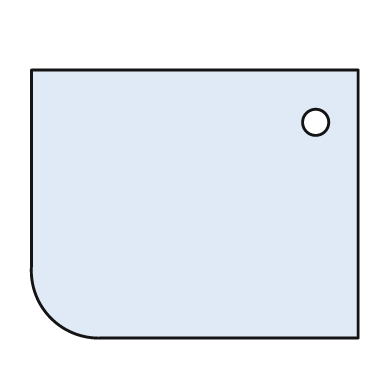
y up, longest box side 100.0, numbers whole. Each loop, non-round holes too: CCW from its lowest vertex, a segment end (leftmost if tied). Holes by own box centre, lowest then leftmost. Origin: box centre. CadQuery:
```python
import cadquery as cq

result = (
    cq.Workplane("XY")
    .moveTo(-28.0, -41.0)
    .lineTo(50.0, -41.0)
    .lineTo(50.0, 41.0)
    .lineTo(-50.0, 41.0)
    .lineTo(-50.0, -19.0)
    .threePointArc((-44.0, -35.0), (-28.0, -41.0))
    .close()
    .moveTo(37.0, 25.0)
    .circle(4.0)
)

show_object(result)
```